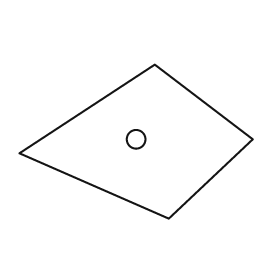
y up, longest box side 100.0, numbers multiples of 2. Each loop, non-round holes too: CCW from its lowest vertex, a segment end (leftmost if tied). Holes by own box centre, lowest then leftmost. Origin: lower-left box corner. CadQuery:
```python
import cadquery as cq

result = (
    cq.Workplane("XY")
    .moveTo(64.0, 0.0)
    .lineTo(100.0, 34.0)
    .lineTo(58.0, 66.0)
    .lineTo(0.0, 28.0)
    .close()
    .moveTo(50.0, 34.0)
    .circle(4.0)
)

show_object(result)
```